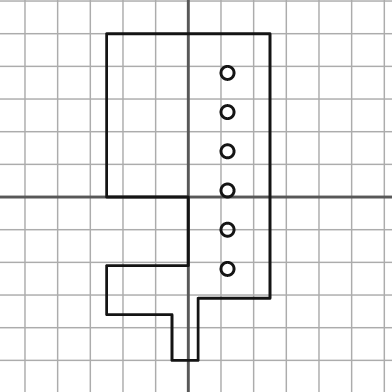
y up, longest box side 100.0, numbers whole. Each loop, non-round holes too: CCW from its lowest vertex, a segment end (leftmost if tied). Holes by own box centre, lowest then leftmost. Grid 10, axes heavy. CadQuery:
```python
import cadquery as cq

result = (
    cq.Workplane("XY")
    .moveTo(-5.0, -50.0)
    .lineTo(3.0, -50.0)
    .lineTo(3.0, -31.0)
    .lineTo(25.0, -31.0)
    .lineTo(25.0, 50.0)
    .lineTo(-25.0, 50.0)
    .lineTo(-25.0, 0.0)
    .lineTo(0.0, 0.0)
    .lineTo(0.0, -21.0)
    .lineTo(-25.0, -21.0)
    .lineTo(-25.0, -36.0)
    .lineTo(-5.0, -36.0)
    .close()
    .moveTo(12.0, -22.0)
    .circle(2.0)
    .moveTo(12.0, -10.0)
    .circle(2.0)
    .moveTo(12.0, 2.0)
    .circle(2.0)
    .moveTo(12.0, 14.0)
    .circle(2.0)
    .moveTo(12.0, 26.0)
    .circle(2.0)
    .moveTo(12.0, 38.0)
    .circle(2.0)
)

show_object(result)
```